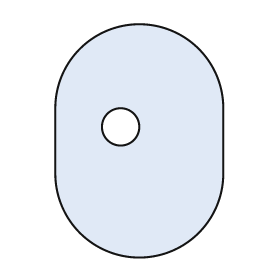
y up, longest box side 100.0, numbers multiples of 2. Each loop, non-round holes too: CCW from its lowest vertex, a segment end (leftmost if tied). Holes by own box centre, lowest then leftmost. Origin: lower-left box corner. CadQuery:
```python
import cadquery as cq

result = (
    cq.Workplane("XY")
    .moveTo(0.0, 36.0)
    .threePointArc((36.0, 0.0), (72.0, 36.0))
    .lineTo(72.0, 64.0)
    .threePointArc((36.0, 100.0), (0.0, 64.0))
    .close()
    .moveTo(28.0, 56.0)
    .circle(8.0)
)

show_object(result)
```